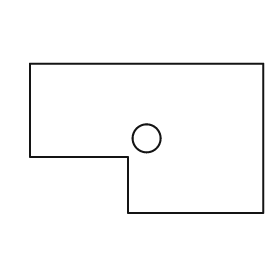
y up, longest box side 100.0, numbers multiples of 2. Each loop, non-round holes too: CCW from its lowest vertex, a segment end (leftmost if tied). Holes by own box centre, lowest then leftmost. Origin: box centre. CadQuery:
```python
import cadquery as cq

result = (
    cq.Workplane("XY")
    .moveTo(-8.0, -32.0)
    .lineTo(50.0, -32.0)
    .lineTo(50.0, 32.0)
    .lineTo(-50.0, 32.0)
    .lineTo(-50.0, -8.0)
    .lineTo(-8.0, -8.0)
    .close()
    .moveTo(0.0, 0.0)
    .circle(6.0)
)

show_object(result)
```